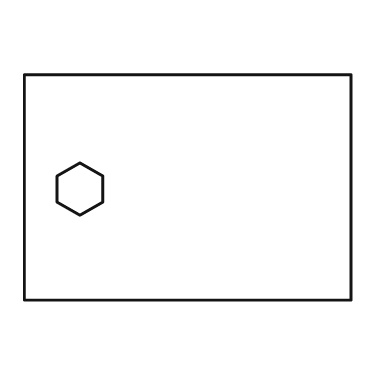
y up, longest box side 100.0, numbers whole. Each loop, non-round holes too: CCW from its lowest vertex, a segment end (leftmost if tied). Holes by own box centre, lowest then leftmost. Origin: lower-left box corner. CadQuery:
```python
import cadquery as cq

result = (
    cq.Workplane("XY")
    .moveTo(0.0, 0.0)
    .lineTo(100.0, 0.0)
    .lineTo(100.0, 69.0)
    .lineTo(0.0, 69.0)
    .close()
    .moveTo(17.0, 26.0)
    .lineTo(24.0, 30.0)
    .lineTo(24.0, 38.0)
    .lineTo(17.0, 42.0)
    .lineTo(10.0, 38.0)
    .lineTo(10.0, 30.0)
    .close()
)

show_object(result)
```